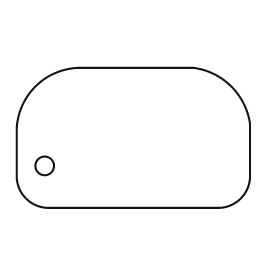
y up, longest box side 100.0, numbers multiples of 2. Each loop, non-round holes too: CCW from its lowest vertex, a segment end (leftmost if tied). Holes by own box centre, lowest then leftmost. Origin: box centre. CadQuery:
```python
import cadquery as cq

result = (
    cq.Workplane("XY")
    .moveTo(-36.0, -30.0)
    .lineTo(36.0, -30.0)
    .threePointArc((46.0, -26.0), (50.0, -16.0))
    .lineTo(50.0, 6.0)
    .threePointArc((42.0, 22.0), (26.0, 30.0))
    .lineTo(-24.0, 30.0)
    .threePointArc((-42.0, 22.0), (-50.0, 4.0))
    .lineTo(-50.0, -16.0)
    .threePointArc((-46.0, -26.0), (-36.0, -30.0))
    .close()
    .moveTo(-38.0, -12.0)
    .circle(4.0)
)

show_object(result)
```